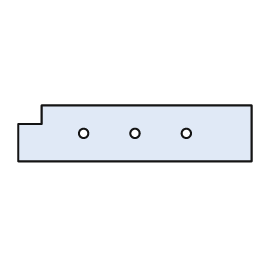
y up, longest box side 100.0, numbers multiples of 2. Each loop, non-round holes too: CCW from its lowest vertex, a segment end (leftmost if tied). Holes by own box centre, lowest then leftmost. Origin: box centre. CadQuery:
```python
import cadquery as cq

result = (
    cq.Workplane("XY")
    .moveTo(-50.0, -12.0)
    .lineTo(50.0, -12.0)
    .lineTo(50.0, 12.0)
    .lineTo(-40.0, 12.0)
    .lineTo(-40.0, 4.0)
    .lineTo(-50.0, 4.0)
    .close()
    .moveTo(-22.0, 0.0)
    .circle(2.0)
    .moveTo(0.0, 0.0)
    .circle(2.0)
    .moveTo(22.0, 0.0)
    .circle(2.0)
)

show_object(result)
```